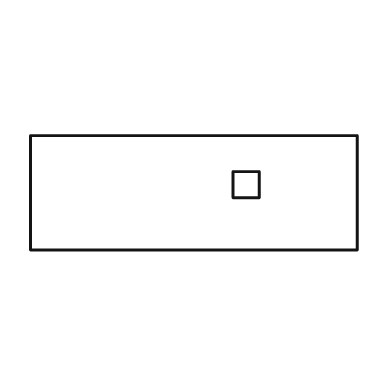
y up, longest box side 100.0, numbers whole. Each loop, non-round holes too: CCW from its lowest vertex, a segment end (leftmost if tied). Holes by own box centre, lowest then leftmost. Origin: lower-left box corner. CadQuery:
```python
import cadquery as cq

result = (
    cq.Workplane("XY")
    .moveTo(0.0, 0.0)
    .lineTo(100.0, 0.0)
    .lineTo(100.0, 35.0)
    .lineTo(0.0, 35.0)
    .close()
    .moveTo(62.0, 16.0)
    .lineTo(70.0, 16.0)
    .lineTo(70.0, 24.0)
    .lineTo(62.0, 24.0)
    .close()
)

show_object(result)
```